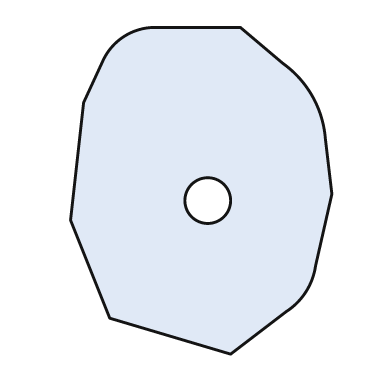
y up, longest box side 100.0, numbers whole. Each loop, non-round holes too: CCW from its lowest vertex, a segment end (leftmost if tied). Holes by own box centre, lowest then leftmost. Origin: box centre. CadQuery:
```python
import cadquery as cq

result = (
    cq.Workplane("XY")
    .moveTo(9.0, -50.0)
    .lineTo(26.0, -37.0)
    .threePointArc((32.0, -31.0), (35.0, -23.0))
    .lineTo(40.0, -1.0)
    .lineTo(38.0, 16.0)
    .threePointArc((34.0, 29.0), (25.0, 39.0))
    .lineTo(12.0, 50.0)
    .lineTo(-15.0, 50.0)
    .threePointArc((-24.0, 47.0), (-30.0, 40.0))
    .lineTo(-36.0, 27.0)
    .lineTo(-40.0, -9.0)
    .lineTo(-28.0, -39.0)
    .close()
    .moveTo(2.0, -3.0)
    .circle(7.0)
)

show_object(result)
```